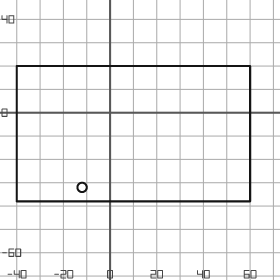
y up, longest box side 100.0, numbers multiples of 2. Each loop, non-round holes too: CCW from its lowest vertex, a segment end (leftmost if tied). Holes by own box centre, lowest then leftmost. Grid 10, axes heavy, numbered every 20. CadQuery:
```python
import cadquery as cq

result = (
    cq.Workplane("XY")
    .moveTo(-40.0, -38.0)
    .lineTo(60.0, -38.0)
    .lineTo(60.0, 20.0)
    .lineTo(-40.0, 20.0)
    .close()
    .moveTo(-12.0, -32.0)
    .circle(2.0)
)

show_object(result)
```